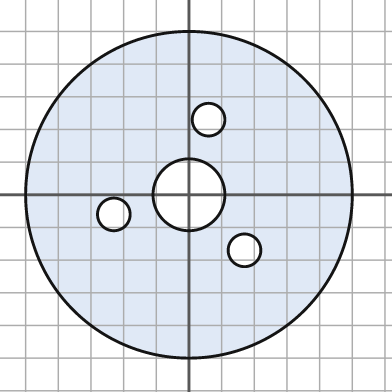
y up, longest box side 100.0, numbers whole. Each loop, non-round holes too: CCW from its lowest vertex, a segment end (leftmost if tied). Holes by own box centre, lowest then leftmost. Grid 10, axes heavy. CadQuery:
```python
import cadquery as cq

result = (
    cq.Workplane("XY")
    .moveTo(0.0, 0.0)
    .circle(50.0)
    .moveTo(17.0, -17.0)
    .circle(5.0)
    .moveTo(-23.0, -6.0)
    .circle(5.0)
    .moveTo(0.0, 0.0)
    .circle(11.0)
    .moveTo(6.0, 23.0)
    .circle(5.0)
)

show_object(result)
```